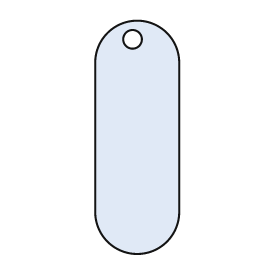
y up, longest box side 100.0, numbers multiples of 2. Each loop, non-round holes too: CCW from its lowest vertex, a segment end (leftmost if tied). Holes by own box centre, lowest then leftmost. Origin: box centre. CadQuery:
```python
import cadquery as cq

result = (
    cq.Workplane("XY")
    .moveTo(-18.0, -32.0)
    .threePointArc((0.0, -50.0), (18.0, -32.0))
    .lineTo(18.0, 32.0)
    .threePointArc((0.0, 50.0), (-18.0, 32.0))
    .close()
    .moveTo(-2.0, 42.0)
    .circle(4.0)
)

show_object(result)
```